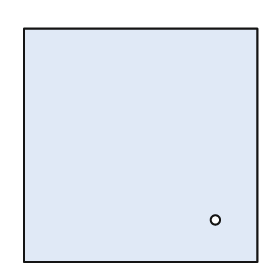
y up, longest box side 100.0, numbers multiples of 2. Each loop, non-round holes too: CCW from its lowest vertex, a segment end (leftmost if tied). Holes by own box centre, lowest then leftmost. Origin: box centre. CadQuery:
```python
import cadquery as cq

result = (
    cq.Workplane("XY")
    .moveTo(-50.0, -50.0)
    .lineTo(50.0, -50.0)
    .lineTo(50.0, 50.0)
    .lineTo(-50.0, 50.0)
    .close()
    .moveTo(32.0, -32.0)
    .circle(2.0)
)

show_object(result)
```